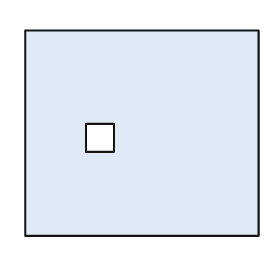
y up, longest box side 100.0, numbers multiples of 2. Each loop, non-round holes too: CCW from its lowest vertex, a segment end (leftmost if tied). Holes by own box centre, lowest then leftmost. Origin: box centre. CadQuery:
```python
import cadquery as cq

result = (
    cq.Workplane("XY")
    .moveTo(-50.0, -44.0)
    .lineTo(50.0, -44.0)
    .lineTo(50.0, 44.0)
    .lineTo(-50.0, 44.0)
    .close()
    .moveTo(-24.0, -8.0)
    .lineTo(-12.0, -8.0)
    .lineTo(-12.0, 4.0)
    .lineTo(-24.0, 4.0)
    .close()
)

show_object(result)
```